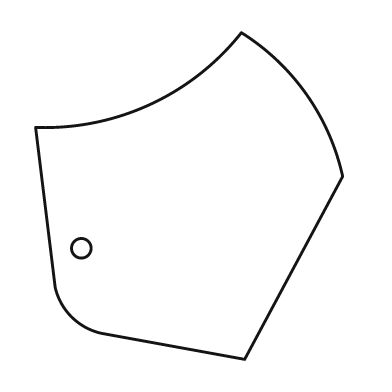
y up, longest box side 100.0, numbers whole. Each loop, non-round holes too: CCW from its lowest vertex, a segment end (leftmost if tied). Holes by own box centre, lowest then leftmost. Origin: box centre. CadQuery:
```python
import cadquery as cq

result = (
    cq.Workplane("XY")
    .moveTo(17.0, -50.0)
    .lineTo(47.0, 6.0)
    .threePointArc((36.0, 31.0), (16.0, 50.0))
    .threePointArc((-12.0, 28.0), (-47.0, 21.0))
    .lineTo(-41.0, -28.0)
    .threePointArc((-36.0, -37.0), (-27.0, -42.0))
    .close()
    .moveTo(-33.0, -16.0)
    .circle(3.0)
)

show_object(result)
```